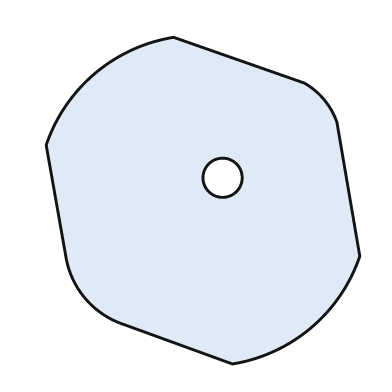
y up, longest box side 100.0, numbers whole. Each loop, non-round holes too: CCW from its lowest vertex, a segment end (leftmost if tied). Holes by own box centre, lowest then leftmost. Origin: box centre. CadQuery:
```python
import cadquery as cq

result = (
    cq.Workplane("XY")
    .moveTo(9.0, -50.0)
    .threePointArc((33.0, -39.0), (48.0, -17.0))
    .lineTo(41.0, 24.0)
    .threePointArc((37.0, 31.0), (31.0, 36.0))
    .lineTo(-9.0, 50.0)
    .threePointArc((-33.0, 39.0), (-48.0, 17.0))
    .lineTo(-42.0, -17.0)
    .threePointArc((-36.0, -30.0), (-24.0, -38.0))
    .close()
    .moveTo(6.0, 7.0)
    .circle(6.0)
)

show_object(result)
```